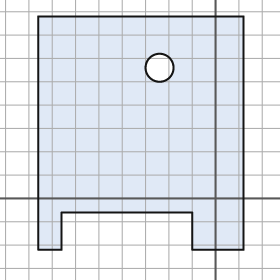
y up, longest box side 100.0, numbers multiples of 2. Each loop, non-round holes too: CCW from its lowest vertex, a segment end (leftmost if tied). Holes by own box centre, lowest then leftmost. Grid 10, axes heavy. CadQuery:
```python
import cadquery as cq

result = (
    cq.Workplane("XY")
    .moveTo(-76.0, -22.0)
    .lineTo(-66.0, -22.0)
    .lineTo(-66.0, -6.0)
    .lineTo(-10.0, -6.0)
    .lineTo(-10.0, -22.0)
    .lineTo(12.0, -22.0)
    .lineTo(12.0, 78.0)
    .lineTo(-76.0, 78.0)
    .close()
    .moveTo(-24.0, 56.0)
    .circle(6.0)
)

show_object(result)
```